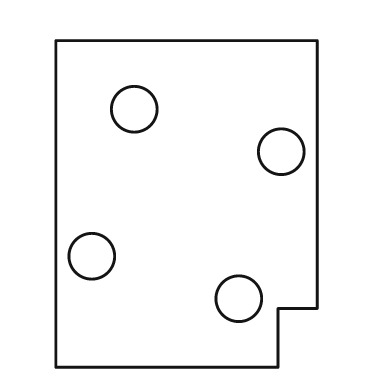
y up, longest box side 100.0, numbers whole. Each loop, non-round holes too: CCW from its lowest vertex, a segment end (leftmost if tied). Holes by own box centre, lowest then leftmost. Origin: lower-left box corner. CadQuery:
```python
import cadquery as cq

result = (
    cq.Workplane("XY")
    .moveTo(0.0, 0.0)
    .lineTo(68.0, 0.0)
    .lineTo(68.0, 18.0)
    .lineTo(80.0, 18.0)
    .lineTo(80.0, 100.0)
    .lineTo(0.0, 100.0)
    .close()
    .moveTo(56.0, 21.0)
    .circle(7.0)
    .moveTo(11.0, 34.0)
    .circle(7.0)
    .moveTo(69.0, 66.0)
    .circle(7.0)
    .moveTo(24.0, 79.0)
    .circle(7.0)
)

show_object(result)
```